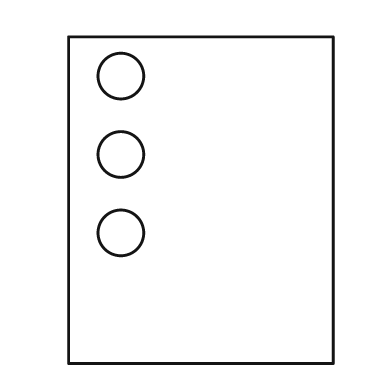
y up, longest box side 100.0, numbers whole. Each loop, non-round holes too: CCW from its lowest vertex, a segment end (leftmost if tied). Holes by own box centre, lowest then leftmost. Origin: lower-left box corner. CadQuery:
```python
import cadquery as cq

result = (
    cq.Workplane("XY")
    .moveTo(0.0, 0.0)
    .lineTo(81.0, 0.0)
    .lineTo(81.0, 100.0)
    .lineTo(0.0, 100.0)
    .close()
    .moveTo(16.0, 40.0)
    .circle(7.0)
    .moveTo(16.0, 64.0)
    .circle(7.0)
    .moveTo(16.0, 88.0)
    .circle(7.0)
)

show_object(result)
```